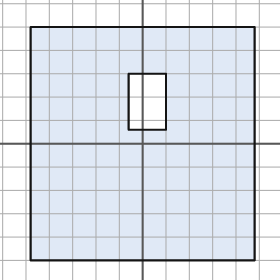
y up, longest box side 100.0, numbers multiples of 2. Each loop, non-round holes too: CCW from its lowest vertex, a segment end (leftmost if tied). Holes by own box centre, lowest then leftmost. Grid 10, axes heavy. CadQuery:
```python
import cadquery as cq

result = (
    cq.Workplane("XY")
    .moveTo(-48.0, -50.0)
    .lineTo(48.0, -50.0)
    .lineTo(48.0, 50.0)
    .lineTo(-48.0, 50.0)
    .close()
    .moveTo(-6.0, 6.0)
    .lineTo(10.0, 6.0)
    .lineTo(10.0, 30.0)
    .lineTo(-6.0, 30.0)
    .close()
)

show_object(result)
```